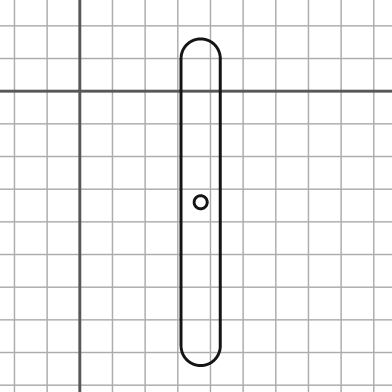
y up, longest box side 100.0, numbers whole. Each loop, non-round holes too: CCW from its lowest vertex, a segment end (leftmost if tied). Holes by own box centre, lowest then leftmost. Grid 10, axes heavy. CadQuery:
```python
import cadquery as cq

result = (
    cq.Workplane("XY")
    .moveTo(31.0, -78.0)
    .threePointArc((37.0, -84.0), (43.0, -78.0))
    .lineTo(43.0, 10.0)
    .threePointArc((37.0, 16.0), (31.0, 10.0))
    .close()
    .moveTo(37.0, -34.0)
    .circle(2.0)
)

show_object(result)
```